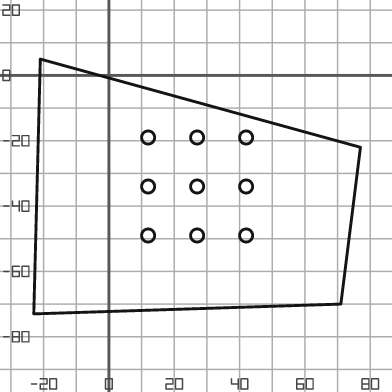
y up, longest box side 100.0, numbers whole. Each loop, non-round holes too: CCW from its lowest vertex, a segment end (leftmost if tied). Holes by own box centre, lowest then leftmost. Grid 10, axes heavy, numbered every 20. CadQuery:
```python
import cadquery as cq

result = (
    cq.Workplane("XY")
    .moveTo(-23.0, -73.0)
    .lineTo(71.0, -70.0)
    .lineTo(77.0, -22.0)
    .lineTo(-21.0, 5.0)
    .close()
    .moveTo(12.0, -49.0)
    .circle(2.0)
    .moveTo(27.0, -49.0)
    .circle(2.0)
    .moveTo(42.0, -49.0)
    .circle(2.0)
    .moveTo(12.0, -34.0)
    .circle(2.0)
    .moveTo(27.0, -34.0)
    .circle(2.0)
    .moveTo(42.0, -34.0)
    .circle(2.0)
    .moveTo(12.0, -19.0)
    .circle(2.0)
    .moveTo(27.0, -19.0)
    .circle(2.0)
    .moveTo(42.0, -19.0)
    .circle(2.0)
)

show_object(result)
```